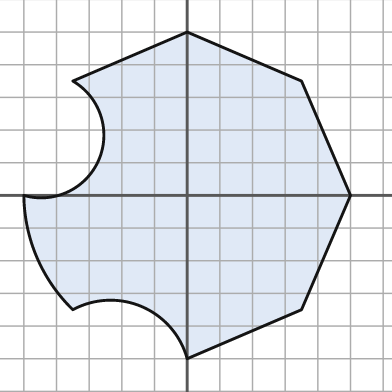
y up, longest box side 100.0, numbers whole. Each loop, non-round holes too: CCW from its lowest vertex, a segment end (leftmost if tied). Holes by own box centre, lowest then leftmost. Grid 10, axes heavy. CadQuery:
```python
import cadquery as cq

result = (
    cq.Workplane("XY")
    .moveTo(0.0, -50.0)
    .lineTo(35.0, -35.0)
    .lineTo(50.0, 0.0)
    .lineTo(35.0, 35.0)
    .lineTo(0.0, 50.0)
    .lineTo(-35.0, 35.0)
    .threePointArc((-27.0, 11.0), (-50.0, 0.0))
    .threePointArc((-46.0, -19.0), (-35.0, -35.0))
    .threePointArc((-14.0, -34.0), (0.0, -50.0))
    .close()
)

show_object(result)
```